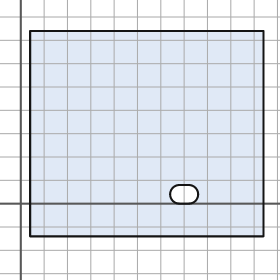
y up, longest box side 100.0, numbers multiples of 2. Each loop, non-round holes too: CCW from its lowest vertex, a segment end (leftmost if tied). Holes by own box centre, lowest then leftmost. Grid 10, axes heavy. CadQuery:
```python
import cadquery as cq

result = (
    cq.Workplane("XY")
    .moveTo(4.0, -14.0)
    .lineTo(104.0, -14.0)
    .lineTo(104.0, 74.0)
    .lineTo(4.0, 74.0)
    .close()
    .moveTo(68.0, 0.0)
    .lineTo(72.0, 0.0)
    .threePointArc((76.0, 4.0), (72.0, 8.0))
    .lineTo(68.0, 8.0)
    .threePointArc((64.0, 4.0), (68.0, 0.0))
    .close()
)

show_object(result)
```